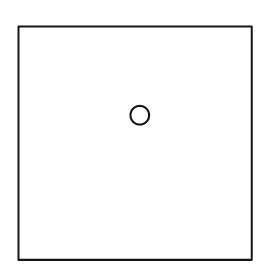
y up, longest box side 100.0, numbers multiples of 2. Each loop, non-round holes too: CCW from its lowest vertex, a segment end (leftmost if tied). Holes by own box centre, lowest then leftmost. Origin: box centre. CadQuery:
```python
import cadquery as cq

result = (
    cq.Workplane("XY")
    .moveTo(-50.0, -50.0)
    .lineTo(50.0, -50.0)
    .lineTo(50.0, 50.0)
    .lineTo(-50.0, 50.0)
    .close()
    .moveTo(2.0, 12.0)
    .circle(4.0)
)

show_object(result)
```